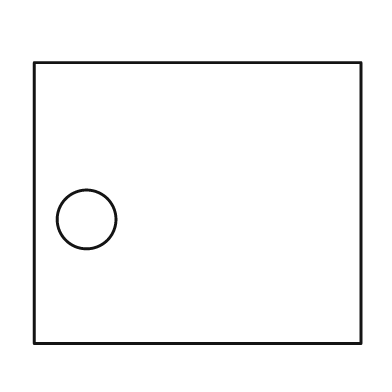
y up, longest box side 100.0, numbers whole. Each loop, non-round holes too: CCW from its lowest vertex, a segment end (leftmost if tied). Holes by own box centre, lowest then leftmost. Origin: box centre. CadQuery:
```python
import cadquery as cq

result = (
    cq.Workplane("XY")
    .moveTo(-50.0, -43.0)
    .lineTo(50.0, -43.0)
    .lineTo(50.0, 43.0)
    .lineTo(-50.0, 43.0)
    .close()
    .moveTo(-34.0, -5.0)
    .circle(9.0)
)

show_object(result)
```